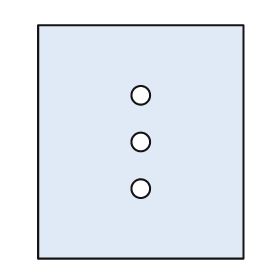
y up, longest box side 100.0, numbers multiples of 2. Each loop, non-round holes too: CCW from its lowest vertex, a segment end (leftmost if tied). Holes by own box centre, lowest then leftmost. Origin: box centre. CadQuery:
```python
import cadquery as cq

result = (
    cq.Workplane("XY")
    .moveTo(-44.0, -50.0)
    .lineTo(44.0, -50.0)
    .lineTo(44.0, 50.0)
    .lineTo(-44.0, 50.0)
    .close()
    .moveTo(0.0, -20.0)
    .circle(4.0)
    .moveTo(0.0, 0.0)
    .circle(4.0)
    .moveTo(0.0, 20.0)
    .circle(4.0)
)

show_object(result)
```